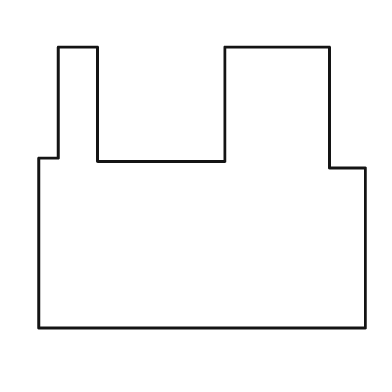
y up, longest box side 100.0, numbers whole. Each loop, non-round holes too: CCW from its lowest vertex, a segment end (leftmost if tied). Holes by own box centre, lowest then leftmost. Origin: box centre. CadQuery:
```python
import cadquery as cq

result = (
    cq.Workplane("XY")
    .moveTo(-50.0, -43.0)
    .lineTo(50.0, -43.0)
    .lineTo(50.0, 6.0)
    .lineTo(39.0, 6.0)
    .lineTo(39.0, 43.0)
    .lineTo(7.0, 43.0)
    .lineTo(7.0, 8.0)
    .lineTo(-32.0, 8.0)
    .lineTo(-32.0, 43.0)
    .lineTo(-44.0, 43.0)
    .lineTo(-44.0, 9.0)
    .lineTo(-50.0, 9.0)
    .close()
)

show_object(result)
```